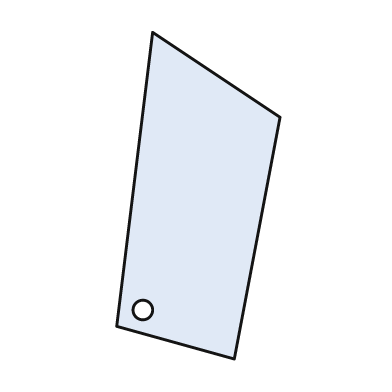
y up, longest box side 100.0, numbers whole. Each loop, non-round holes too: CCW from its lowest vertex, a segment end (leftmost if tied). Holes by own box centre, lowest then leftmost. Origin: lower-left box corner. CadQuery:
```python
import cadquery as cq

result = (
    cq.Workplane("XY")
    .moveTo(36.0, 0.0)
    .lineTo(50.0, 74.0)
    .lineTo(11.0, 100.0)
    .lineTo(0.0, 10.0)
    .close()
    .moveTo(8.0, 15.0)
    .circle(3.0)
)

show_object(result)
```